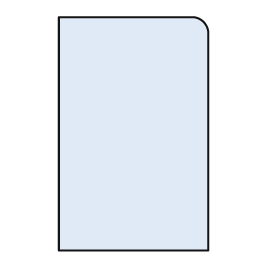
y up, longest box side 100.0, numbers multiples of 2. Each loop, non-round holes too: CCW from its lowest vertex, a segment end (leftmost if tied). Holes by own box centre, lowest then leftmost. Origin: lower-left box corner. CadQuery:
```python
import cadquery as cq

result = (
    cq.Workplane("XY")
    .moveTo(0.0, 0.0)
    .lineTo(64.0, 0.0)
    .lineTo(64.0, 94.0)
    .threePointArc((62.0, 98.0), (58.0, 100.0))
    .lineTo(0.0, 100.0)
    .close()
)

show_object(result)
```